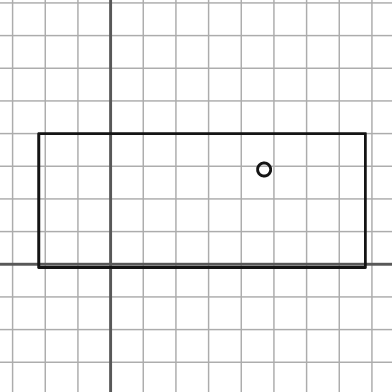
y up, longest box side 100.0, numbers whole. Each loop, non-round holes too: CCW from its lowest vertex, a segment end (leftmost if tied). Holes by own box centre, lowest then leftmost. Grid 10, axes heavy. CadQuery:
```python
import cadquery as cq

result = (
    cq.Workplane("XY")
    .moveTo(-22.0, -1.0)
    .lineTo(78.0, -1.0)
    .lineTo(78.0, 40.0)
    .lineTo(-22.0, 40.0)
    .close()
    .moveTo(47.0, 29.0)
    .circle(2.0)
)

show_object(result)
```